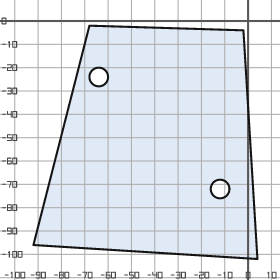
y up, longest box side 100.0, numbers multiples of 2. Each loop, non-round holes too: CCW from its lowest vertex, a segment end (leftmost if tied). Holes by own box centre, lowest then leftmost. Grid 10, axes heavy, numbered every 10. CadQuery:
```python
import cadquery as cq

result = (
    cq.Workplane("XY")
    .moveTo(4.0, -102.0)
    .lineTo(-2.0, -4.0)
    .lineTo(-68.0, -2.0)
    .lineTo(-92.0, -96.0)
    .close()
    .moveTo(-12.0, -72.0)
    .circle(4.0)
    .moveTo(-64.0, -24.0)
    .circle(4.0)
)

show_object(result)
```